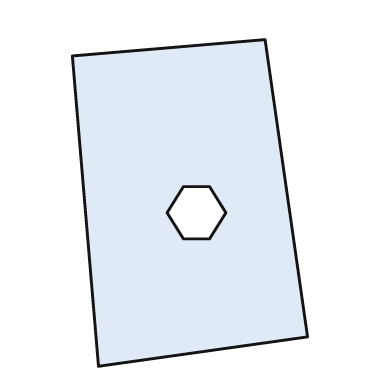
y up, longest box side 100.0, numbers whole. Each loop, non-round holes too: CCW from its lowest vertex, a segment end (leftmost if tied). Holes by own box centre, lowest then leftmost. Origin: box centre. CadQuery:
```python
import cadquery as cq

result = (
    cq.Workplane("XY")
    .moveTo(-28.0, -50.0)
    .lineTo(36.0, -41.0)
    .lineTo(23.0, 50.0)
    .lineTo(-36.0, 45.0)
    .close()
    .moveTo(-2.0, -11.0)
    .lineTo(6.0, -11.0)
    .lineTo(11.0, -3.0)
    .lineTo(6.0, 5.0)
    .lineTo(-2.0, 5.0)
    .lineTo(-7.0, -3.0)
    .close()
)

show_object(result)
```